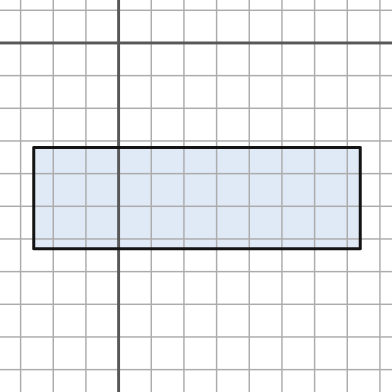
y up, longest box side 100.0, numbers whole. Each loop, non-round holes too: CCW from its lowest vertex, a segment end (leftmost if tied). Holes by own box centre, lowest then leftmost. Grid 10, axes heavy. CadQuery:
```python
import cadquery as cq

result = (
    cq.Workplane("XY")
    .moveTo(-26.0, -63.0)
    .lineTo(74.0, -63.0)
    .lineTo(74.0, -32.0)
    .lineTo(-26.0, -32.0)
    .close()
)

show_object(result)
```